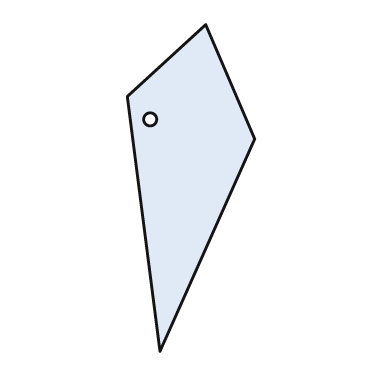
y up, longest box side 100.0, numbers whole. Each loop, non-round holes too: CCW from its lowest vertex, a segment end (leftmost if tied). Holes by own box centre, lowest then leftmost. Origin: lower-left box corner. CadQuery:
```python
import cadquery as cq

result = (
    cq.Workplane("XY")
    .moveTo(10.0, 0.0)
    .lineTo(39.0, 65.0)
    .lineTo(24.0, 100.0)
    .lineTo(0.0, 78.0)
    .close()
    .moveTo(7.0, 71.0)
    .circle(2.0)
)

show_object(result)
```